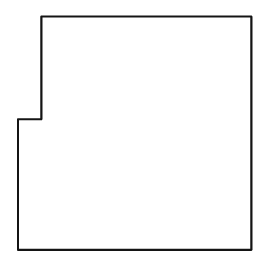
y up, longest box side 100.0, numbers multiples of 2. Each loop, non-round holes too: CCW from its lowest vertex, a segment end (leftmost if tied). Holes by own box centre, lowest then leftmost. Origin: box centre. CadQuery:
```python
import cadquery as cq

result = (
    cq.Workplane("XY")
    .moveTo(-50.0, -50.0)
    .lineTo(50.0, -50.0)
    .lineTo(50.0, 50.0)
    .lineTo(-40.0, 50.0)
    .lineTo(-40.0, 6.0)
    .lineTo(-50.0, 6.0)
    .close()
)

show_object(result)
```